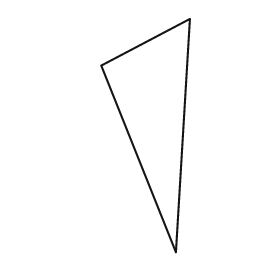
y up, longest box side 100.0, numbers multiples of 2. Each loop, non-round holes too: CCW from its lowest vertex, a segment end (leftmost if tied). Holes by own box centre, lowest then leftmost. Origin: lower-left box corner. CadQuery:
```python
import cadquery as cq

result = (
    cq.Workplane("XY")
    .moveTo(32.0, 0.0)
    .lineTo(38.0, 100.0)
    .lineTo(0.0, 80.0)
    .close()
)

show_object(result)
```